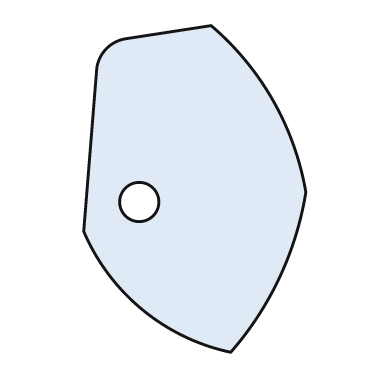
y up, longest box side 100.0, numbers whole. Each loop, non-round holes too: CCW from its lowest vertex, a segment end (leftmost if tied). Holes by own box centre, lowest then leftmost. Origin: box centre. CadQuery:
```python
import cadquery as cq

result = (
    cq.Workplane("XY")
    .moveTo(11.0, -50.0)
    .threePointArc((26.0, -27.0), (34.0, -1.0))
    .threePointArc((24.0, 27.0), (5.0, 50.0))
    .lineTo(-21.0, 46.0)
    .threePointArc((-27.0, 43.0), (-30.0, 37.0))
    .lineTo(-34.0, -13.0)
    .threePointArc((-16.0, -37.0), (11.0, -50.0))
    .close()
    .moveTo(-17.0, -4.0)
    .circle(6.0)
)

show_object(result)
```